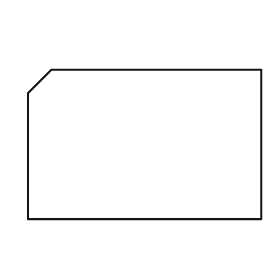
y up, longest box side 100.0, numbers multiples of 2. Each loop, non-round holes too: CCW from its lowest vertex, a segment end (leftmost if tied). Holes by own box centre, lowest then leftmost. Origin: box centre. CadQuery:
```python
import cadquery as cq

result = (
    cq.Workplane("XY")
    .moveTo(-50.0, -32.0)
    .lineTo(50.0, -32.0)
    .lineTo(50.0, 32.0)
    .lineTo(-40.0, 32.0)
    .lineTo(-50.0, 22.0)
    .close()
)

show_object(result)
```